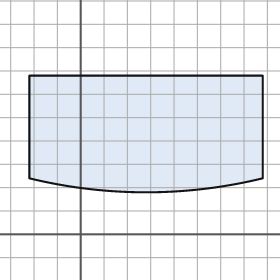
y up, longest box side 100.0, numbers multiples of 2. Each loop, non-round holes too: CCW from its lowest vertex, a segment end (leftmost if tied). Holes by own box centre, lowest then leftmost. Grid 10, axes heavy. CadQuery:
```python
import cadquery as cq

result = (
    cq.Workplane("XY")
    .moveTo(-22.0, 24.0)
    .threePointArc((28.0, 18.0), (78.0, 24.0))
    .lineTo(78.0, 68.0)
    .lineTo(-22.0, 68.0)
    .close()
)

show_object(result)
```